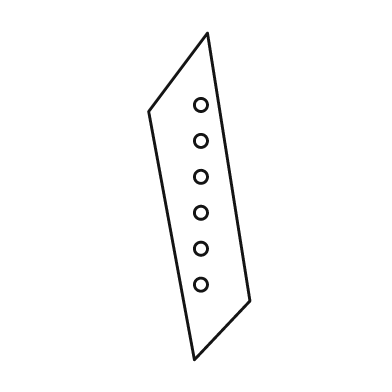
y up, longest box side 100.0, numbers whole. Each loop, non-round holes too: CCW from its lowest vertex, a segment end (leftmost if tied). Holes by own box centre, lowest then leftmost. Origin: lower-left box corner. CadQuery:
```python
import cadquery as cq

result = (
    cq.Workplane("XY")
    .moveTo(14.0, 0.0)
    .lineTo(31.0, 18.0)
    .lineTo(18.0, 100.0)
    .lineTo(0.0, 76.0)
    .close()
    .moveTo(16.0, 23.0)
    .circle(2.0)
    .moveTo(16.0, 34.0)
    .circle(2.0)
    .moveTo(16.0, 45.0)
    .circle(2.0)
    .moveTo(16.0, 56.0)
    .circle(2.0)
    .moveTo(16.0, 67.0)
    .circle(2.0)
    .moveTo(16.0, 78.0)
    .circle(2.0)
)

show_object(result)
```